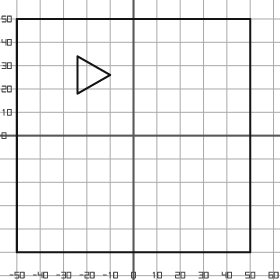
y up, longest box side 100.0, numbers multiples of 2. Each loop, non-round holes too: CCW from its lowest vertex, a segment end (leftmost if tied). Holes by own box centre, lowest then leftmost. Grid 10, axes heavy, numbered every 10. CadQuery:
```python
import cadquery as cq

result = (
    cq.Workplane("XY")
    .moveTo(-50.0, -50.0)
    .lineTo(50.0, -50.0)
    .lineTo(50.0, 50.0)
    .lineTo(-50.0, 50.0)
    .close()
    .moveTo(-24.0, 18.0)
    .lineTo(-10.0, 26.0)
    .lineTo(-24.0, 34.0)
    .close()
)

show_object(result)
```